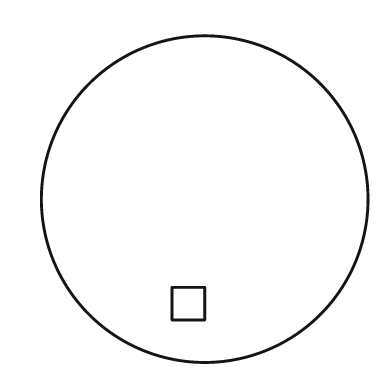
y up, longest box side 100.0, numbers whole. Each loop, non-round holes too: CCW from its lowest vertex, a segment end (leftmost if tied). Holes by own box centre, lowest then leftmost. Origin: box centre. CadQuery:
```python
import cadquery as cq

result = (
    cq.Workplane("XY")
    .moveTo(0.0, 0.0)
    .circle(50.0)
    .moveTo(-10.0, -37.0)
    .lineTo(0.0, -37.0)
    .lineTo(0.0, -27.0)
    .lineTo(-10.0, -27.0)
    .close()
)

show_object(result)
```